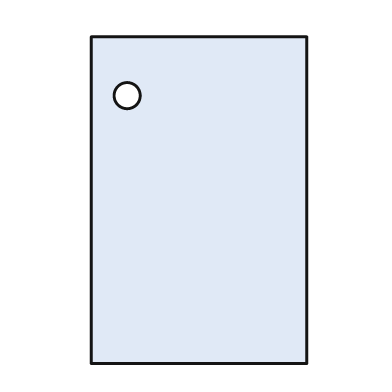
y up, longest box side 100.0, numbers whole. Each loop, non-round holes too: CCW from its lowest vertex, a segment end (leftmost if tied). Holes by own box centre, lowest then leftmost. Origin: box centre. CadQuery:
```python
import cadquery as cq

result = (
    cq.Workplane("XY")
    .moveTo(-33.0, -50.0)
    .lineTo(33.0, -50.0)
    .lineTo(33.0, 50.0)
    .lineTo(-33.0, 50.0)
    .close()
    .moveTo(-22.0, 32.0)
    .circle(4.0)
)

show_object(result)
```